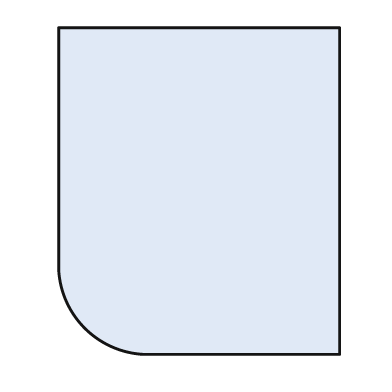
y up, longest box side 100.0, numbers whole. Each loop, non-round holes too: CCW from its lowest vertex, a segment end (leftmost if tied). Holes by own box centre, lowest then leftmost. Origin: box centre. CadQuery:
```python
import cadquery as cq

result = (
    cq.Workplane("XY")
    .moveTo(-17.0, -50.0)
    .lineTo(43.0, -50.0)
    .lineTo(43.0, 50.0)
    .lineTo(-43.0, 50.0)
    .lineTo(-43.0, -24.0)
    .threePointArc((-35.0, -42.0), (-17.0, -50.0))
    .close()
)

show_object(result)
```